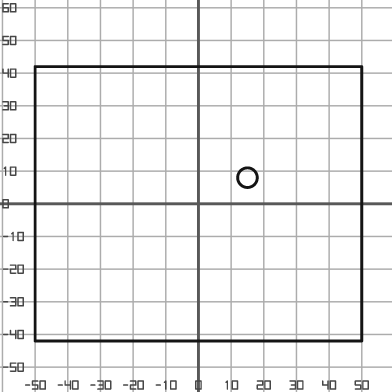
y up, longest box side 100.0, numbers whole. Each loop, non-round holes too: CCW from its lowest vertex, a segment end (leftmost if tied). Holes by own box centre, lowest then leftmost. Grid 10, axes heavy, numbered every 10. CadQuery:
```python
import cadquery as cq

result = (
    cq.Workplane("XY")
    .moveTo(-50.0, -42.0)
    .lineTo(50.0, -42.0)
    .lineTo(50.0, 42.0)
    .lineTo(-50.0, 42.0)
    .close()
    .moveTo(15.0, 8.0)
    .circle(3.0)
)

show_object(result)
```